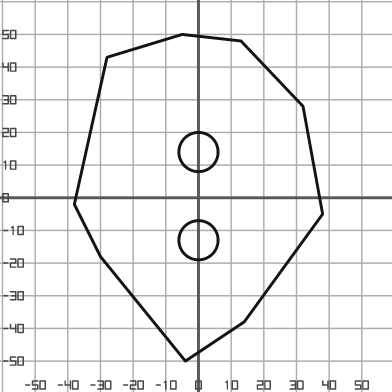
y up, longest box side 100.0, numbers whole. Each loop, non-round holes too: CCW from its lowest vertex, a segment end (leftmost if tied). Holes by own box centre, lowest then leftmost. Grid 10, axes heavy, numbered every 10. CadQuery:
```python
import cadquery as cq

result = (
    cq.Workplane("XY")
    .moveTo(-4.0, -50.0)
    .lineTo(14.0, -38.0)
    .lineTo(38.0, -5.0)
    .lineTo(32.0, 28.0)
    .lineTo(13.0, 48.0)
    .lineTo(-5.0, 50.0)
    .lineTo(-28.0, 43.0)
    .lineTo(-38.0, -2.0)
    .lineTo(-30.0, -18.0)
    .close()
    .moveTo(0.0, -13.0)
    .circle(6.0)
    .moveTo(0.0, 14.0)
    .circle(6.0)
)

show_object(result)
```